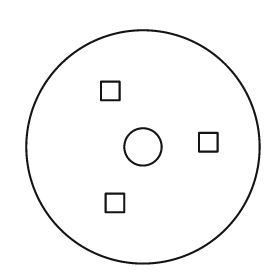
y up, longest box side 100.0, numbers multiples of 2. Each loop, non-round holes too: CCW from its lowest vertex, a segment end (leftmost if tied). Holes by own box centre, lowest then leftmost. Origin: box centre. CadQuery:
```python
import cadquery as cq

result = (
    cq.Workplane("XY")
    .moveTo(0.0, 0.0)
    .circle(50.0)
    .moveTo(-16.0, -28.0)
    .lineTo(-8.0, -28.0)
    .lineTo(-8.0, -20.0)
    .lineTo(-16.0, -20.0)
    .close()
    .moveTo(0.0, 0.0)
    .circle(8.0)
    .moveTo(24.0, -2.0)
    .lineTo(32.0, -2.0)
    .lineTo(32.0, 6.0)
    .lineTo(24.0, 6.0)
    .close()
    .moveTo(-18.0, 20.0)
    .lineTo(-10.0, 20.0)
    .lineTo(-10.0, 28.0)
    .lineTo(-18.0, 28.0)
    .close()
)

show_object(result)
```